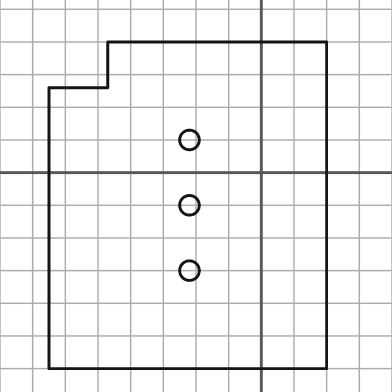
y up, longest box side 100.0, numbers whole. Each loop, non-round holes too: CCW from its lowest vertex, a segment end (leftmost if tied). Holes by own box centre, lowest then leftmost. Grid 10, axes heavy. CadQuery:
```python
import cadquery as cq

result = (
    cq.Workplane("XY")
    .moveTo(-65.0, -60.0)
    .lineTo(20.0, -60.0)
    .lineTo(20.0, 40.0)
    .lineTo(-47.0, 40.0)
    .lineTo(-47.0, 26.0)
    .lineTo(-65.0, 26.0)
    .close()
    .moveTo(-22.0, -30.0)
    .circle(3.0)
    .moveTo(-22.0, -10.0)
    .circle(3.0)
    .moveTo(-22.0, 10.0)
    .circle(3.0)
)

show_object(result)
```